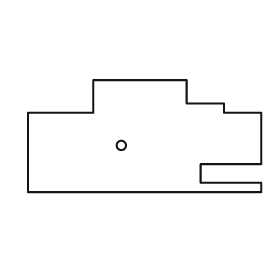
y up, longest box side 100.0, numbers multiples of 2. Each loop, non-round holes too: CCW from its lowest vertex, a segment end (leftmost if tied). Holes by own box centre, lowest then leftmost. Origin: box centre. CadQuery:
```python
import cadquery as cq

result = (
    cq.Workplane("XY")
    .moveTo(-50.0, -24.0)
    .lineTo(50.0, -24.0)
    .lineTo(50.0, -20.0)
    .lineTo(24.0, -20.0)
    .lineTo(24.0, -12.0)
    .lineTo(50.0, -12.0)
    .lineTo(50.0, 10.0)
    .lineTo(34.0, 10.0)
    .lineTo(34.0, 14.0)
    .lineTo(18.0, 14.0)
    .lineTo(18.0, 24.0)
    .lineTo(-22.0, 24.0)
    .lineTo(-22.0, 10.0)
    .lineTo(-50.0, 10.0)
    .close()
    .moveTo(-10.0, -4.0)
    .circle(2.0)
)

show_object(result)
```